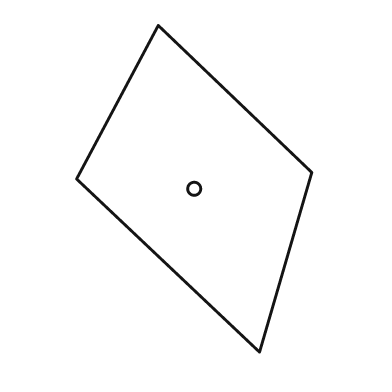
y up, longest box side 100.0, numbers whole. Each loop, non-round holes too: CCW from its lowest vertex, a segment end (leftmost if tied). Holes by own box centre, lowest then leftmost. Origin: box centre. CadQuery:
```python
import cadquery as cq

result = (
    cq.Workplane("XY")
    .moveTo(20.0, -50.0)
    .lineTo(36.0, 5.0)
    .lineTo(-11.0, 50.0)
    .lineTo(-36.0, 3.0)
    .close()
    .moveTo(0.0, 0.0)
    .circle(2.0)
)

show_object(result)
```